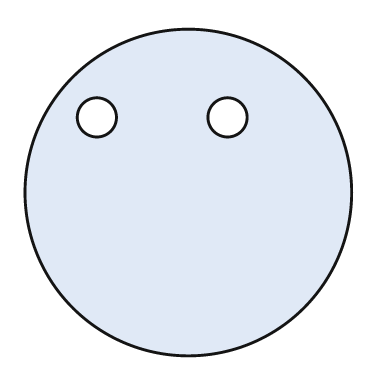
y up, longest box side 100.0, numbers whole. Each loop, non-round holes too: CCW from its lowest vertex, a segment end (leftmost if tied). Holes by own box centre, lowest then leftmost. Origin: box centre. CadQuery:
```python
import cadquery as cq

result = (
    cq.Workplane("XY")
    .moveTo(0.0, 0.0)
    .circle(50.0)
    .moveTo(-28.0, 23.0)
    .circle(6.0)
    .moveTo(12.0, 23.0)
    .circle(6.0)
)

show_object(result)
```